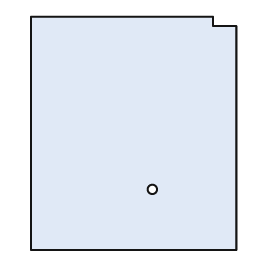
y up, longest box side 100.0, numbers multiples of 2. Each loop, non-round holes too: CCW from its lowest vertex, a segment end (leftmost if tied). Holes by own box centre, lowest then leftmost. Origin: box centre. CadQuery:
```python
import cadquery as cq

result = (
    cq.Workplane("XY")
    .moveTo(-44.0, -50.0)
    .lineTo(44.0, -50.0)
    .lineTo(44.0, 46.0)
    .lineTo(34.0, 46.0)
    .lineTo(34.0, 50.0)
    .lineTo(-44.0, 50.0)
    .close()
    .moveTo(8.0, -24.0)
    .circle(2.0)
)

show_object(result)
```